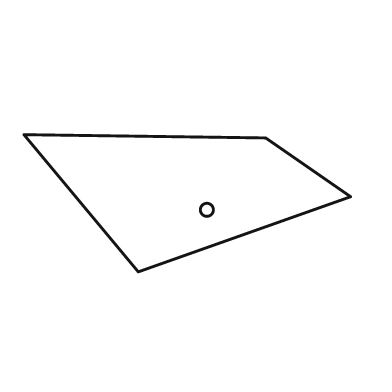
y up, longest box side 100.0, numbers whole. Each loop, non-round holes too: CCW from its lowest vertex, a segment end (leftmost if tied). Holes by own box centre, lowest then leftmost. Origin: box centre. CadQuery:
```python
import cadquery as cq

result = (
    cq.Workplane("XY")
    .moveTo(-15.0, -21.0)
    .lineTo(50.0, 2.0)
    .lineTo(24.0, 20.0)
    .lineTo(-50.0, 21.0)
    .close()
    .moveTo(6.0, -2.0)
    .circle(2.0)
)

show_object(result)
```